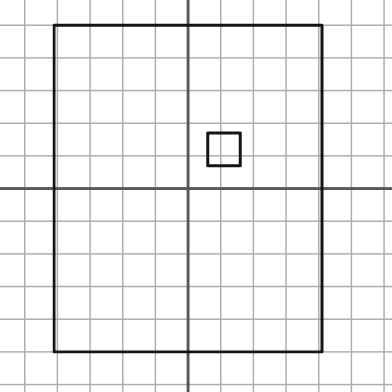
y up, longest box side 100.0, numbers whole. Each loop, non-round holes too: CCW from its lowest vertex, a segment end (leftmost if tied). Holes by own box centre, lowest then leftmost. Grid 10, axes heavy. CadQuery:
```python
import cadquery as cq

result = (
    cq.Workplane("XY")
    .moveTo(-41.0, -50.0)
    .lineTo(41.0, -50.0)
    .lineTo(41.0, 50.0)
    .lineTo(-41.0, 50.0)
    .close()
    .moveTo(6.0, 7.0)
    .lineTo(16.0, 7.0)
    .lineTo(16.0, 17.0)
    .lineTo(6.0, 17.0)
    .close()
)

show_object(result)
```